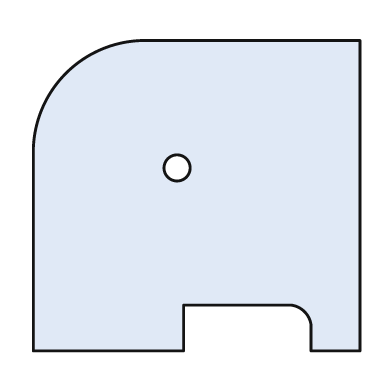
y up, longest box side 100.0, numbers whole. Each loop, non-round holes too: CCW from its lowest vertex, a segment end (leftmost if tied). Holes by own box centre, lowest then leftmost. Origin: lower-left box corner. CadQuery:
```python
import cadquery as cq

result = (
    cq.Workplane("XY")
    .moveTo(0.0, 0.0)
    .lineTo(46.0, 0.0)
    .lineTo(46.0, 14.0)
    .lineTo(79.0, 14.0)
    .threePointArc((83.0, 12.0), (85.0, 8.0))
    .lineTo(85.0, 0.0)
    .lineTo(100.0, 0.0)
    .lineTo(100.0, 95.0)
    .lineTo(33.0, 95.0)
    .threePointArc((10.0, 85.0), (0.0, 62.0))
    .close()
    .moveTo(44.0, 56.0)
    .circle(4.0)
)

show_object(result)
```